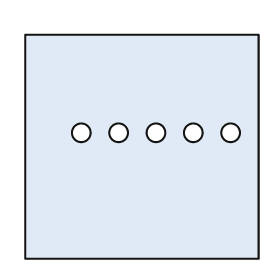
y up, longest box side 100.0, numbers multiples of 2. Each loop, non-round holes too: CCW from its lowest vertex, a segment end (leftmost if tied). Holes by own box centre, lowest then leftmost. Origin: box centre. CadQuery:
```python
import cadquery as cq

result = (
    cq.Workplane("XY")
    .moveTo(-50.0, -48.0)
    .lineTo(50.0, -48.0)
    .lineTo(50.0, 48.0)
    .lineTo(-50.0, 48.0)
    .close()
    .moveTo(-26.0, 6.0)
    .circle(4.0)
    .moveTo(-10.0, 6.0)
    .circle(4.0)
    .moveTo(6.0, 6.0)
    .circle(4.0)
    .moveTo(22.0, 6.0)
    .circle(4.0)
    .moveTo(38.0, 6.0)
    .circle(4.0)
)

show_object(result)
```